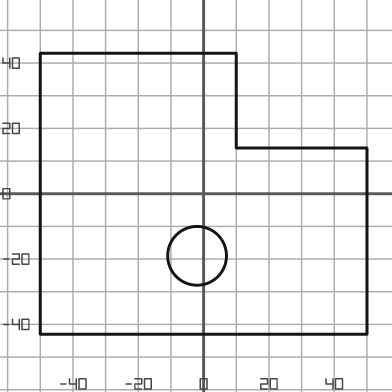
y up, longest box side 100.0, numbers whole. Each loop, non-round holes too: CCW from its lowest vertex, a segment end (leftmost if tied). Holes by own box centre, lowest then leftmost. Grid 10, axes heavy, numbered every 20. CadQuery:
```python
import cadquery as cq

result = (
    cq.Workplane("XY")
    .moveTo(-50.0, -43.0)
    .lineTo(50.0, -43.0)
    .lineTo(50.0, 14.0)
    .lineTo(10.0, 14.0)
    .lineTo(10.0, 43.0)
    .lineTo(-50.0, 43.0)
    .close()
    .moveTo(-2.0, -19.0)
    .circle(9.0)
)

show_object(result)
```